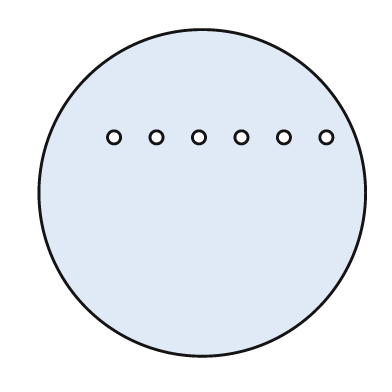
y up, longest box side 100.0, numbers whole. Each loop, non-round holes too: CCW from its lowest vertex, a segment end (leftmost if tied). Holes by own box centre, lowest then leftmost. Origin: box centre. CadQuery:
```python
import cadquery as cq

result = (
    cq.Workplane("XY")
    .moveTo(0.0, 0.0)
    .circle(50.0)
    .moveTo(-27.0, 17.0)
    .circle(2.0)
    .moveTo(-14.0, 17.0)
    .circle(2.0)
    .moveTo(-1.0, 17.0)
    .circle(2.0)
    .moveTo(12.0, 17.0)
    .circle(2.0)
    .moveTo(25.0, 17.0)
    .circle(2.0)
    .moveTo(38.0, 17.0)
    .circle(2.0)
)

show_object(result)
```